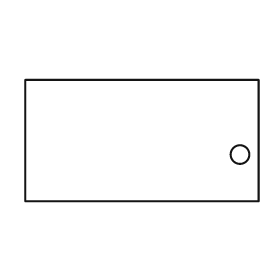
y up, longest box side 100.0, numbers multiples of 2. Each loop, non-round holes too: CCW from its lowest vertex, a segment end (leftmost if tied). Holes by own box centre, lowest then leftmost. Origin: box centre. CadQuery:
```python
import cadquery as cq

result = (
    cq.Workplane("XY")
    .moveTo(-50.0, -26.0)
    .lineTo(50.0, -26.0)
    .lineTo(50.0, 26.0)
    .lineTo(-50.0, 26.0)
    .close()
    .moveTo(42.0, -6.0)
    .circle(4.0)
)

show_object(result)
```